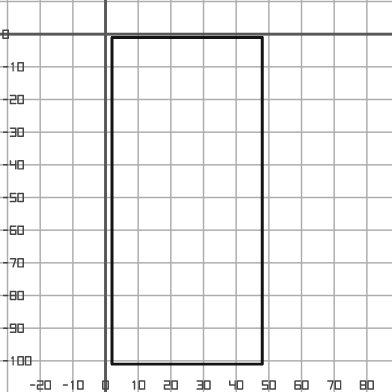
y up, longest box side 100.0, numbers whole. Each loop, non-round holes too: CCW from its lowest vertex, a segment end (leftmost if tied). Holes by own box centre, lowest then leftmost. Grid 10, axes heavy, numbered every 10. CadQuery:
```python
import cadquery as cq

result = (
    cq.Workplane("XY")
    .moveTo(2.0, -101.0)
    .lineTo(48.0, -101.0)
    .lineTo(48.0, -1.0)
    .lineTo(2.0, -1.0)
    .close()
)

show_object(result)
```